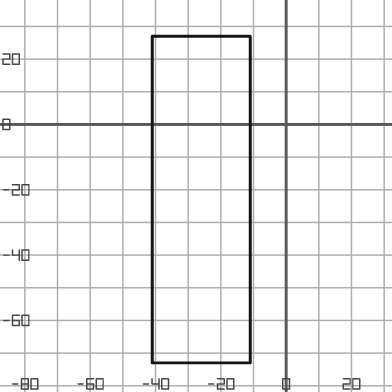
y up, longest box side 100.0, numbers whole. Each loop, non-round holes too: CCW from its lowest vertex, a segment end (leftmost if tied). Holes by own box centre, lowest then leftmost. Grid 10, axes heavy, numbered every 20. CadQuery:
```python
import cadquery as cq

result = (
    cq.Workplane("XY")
    .moveTo(-41.0, -73.0)
    .lineTo(-11.0, -73.0)
    .lineTo(-11.0, 27.0)
    .lineTo(-41.0, 27.0)
    .close()
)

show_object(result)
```